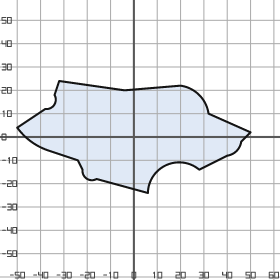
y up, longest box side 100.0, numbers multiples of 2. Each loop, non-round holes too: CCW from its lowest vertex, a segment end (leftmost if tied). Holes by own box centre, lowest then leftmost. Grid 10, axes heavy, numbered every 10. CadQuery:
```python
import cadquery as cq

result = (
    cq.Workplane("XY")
    .moveTo(6.0, -24.0)
    .threePointArc((14.0, -12.0), (28.0, -14.0))
    .lineTo(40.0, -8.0)
    .threePointArc((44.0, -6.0), (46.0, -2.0))
    .lineTo(50.0, 2.0)
    .lineTo(32.0, 10.0)
    .threePointArc((28.0, 18.0), (20.0, 22.0))
    .lineTo(-4.0, 20.0)
    .lineTo(-32.0, 24.0)
    .lineTo(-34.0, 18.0)
    .threePointArc((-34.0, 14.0), (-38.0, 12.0))
    .lineTo(-50.0, 4.0)
    .threePointArc((-44.0, -2.0), (-36.0, -6.0))
    .lineTo(-24.0, -10.0)
    .lineTo(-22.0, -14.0)
    .threePointArc((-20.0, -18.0), (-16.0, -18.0))
    .close()
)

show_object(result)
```